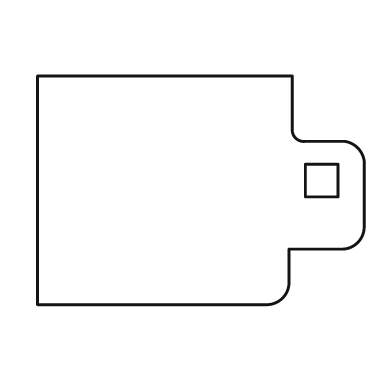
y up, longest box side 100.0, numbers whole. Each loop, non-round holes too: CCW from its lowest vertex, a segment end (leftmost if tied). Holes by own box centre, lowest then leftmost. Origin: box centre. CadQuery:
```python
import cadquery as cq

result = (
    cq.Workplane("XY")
    .moveTo(-50.0, -35.0)
    .lineTo(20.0, -35.0)
    .threePointArc((25.0, -33.0), (27.0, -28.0))
    .lineTo(27.0, -18.0)
    .lineTo(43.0, -18.0)
    .threePointArc((48.0, -16.0), (50.0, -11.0))
    .lineTo(50.0, 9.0)
    .threePointArc((48.0, 13.0), (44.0, 15.0))
    .lineTo(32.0, 15.0)
    .threePointArc((29.0, 16.0), (28.0, 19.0))
    .lineTo(28.0, 35.0)
    .lineTo(-50.0, 35.0)
    .close()
    .moveTo(32.0, -2.0)
    .lineTo(42.0, -2.0)
    .lineTo(42.0, 8.0)
    .lineTo(32.0, 8.0)
    .close()
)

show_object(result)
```